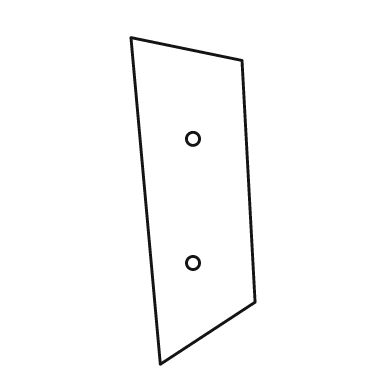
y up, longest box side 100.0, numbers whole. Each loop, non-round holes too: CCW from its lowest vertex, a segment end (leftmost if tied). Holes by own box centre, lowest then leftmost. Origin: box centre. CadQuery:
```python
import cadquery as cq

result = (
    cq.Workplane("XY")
    .moveTo(-10.0, -50.0)
    .lineTo(19.0, -31.0)
    .lineTo(15.0, 43.0)
    .lineTo(-19.0, 50.0)
    .close()
    .moveTo(0.0, -19.0)
    .circle(2.0)
    .moveTo(0.0, 19.0)
    .circle(2.0)
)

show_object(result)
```